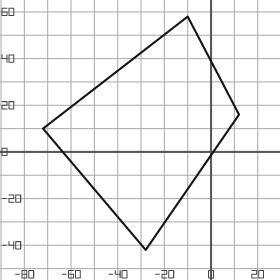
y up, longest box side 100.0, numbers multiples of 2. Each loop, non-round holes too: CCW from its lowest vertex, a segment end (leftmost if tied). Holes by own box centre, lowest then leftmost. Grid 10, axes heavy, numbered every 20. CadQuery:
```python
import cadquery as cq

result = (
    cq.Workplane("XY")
    .moveTo(-28.0, -42.0)
    .lineTo(12.0, 16.0)
    .lineTo(-10.0, 58.0)
    .lineTo(-72.0, 10.0)
    .close()
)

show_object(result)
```